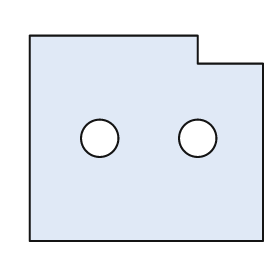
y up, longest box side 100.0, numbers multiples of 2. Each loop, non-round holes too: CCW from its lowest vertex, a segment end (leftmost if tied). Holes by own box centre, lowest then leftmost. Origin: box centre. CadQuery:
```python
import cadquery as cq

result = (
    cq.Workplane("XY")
    .moveTo(-50.0, -44.0)
    .lineTo(50.0, -44.0)
    .lineTo(50.0, 32.0)
    .lineTo(22.0, 32.0)
    .lineTo(22.0, 44.0)
    .lineTo(-50.0, 44.0)
    .close()
    .moveTo(-20.0, 0.0)
    .circle(8.0)
    .moveTo(22.0, 0.0)
    .circle(8.0)
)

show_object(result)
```